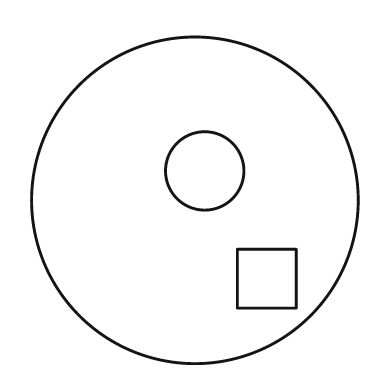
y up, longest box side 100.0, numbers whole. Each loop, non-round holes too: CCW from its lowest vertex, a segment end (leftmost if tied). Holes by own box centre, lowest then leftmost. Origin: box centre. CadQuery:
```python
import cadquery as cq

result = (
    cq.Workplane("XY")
    .moveTo(0.0, 0.0)
    .circle(50.0)
    .moveTo(13.0, -33.0)
    .lineTo(31.0, -33.0)
    .lineTo(31.0, -15.0)
    .lineTo(13.0, -15.0)
    .close()
    .moveTo(3.0, 9.0)
    .circle(12.0)
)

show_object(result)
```